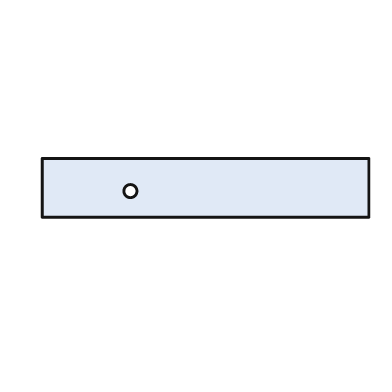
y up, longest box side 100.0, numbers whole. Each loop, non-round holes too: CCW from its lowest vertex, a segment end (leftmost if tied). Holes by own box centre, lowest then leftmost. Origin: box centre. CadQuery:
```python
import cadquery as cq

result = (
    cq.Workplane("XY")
    .moveTo(-50.0, -9.0)
    .lineTo(50.0, -9.0)
    .lineTo(50.0, 9.0)
    .lineTo(-50.0, 9.0)
    .close()
    .moveTo(-23.0, -1.0)
    .circle(2.0)
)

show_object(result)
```